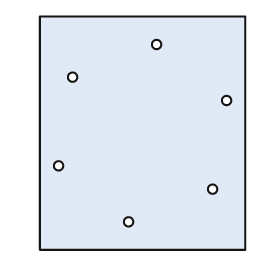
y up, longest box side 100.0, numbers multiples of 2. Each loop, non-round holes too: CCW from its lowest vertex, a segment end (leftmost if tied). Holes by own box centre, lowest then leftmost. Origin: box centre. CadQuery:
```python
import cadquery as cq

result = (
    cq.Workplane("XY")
    .moveTo(-44.0, -50.0)
    .lineTo(44.0, -50.0)
    .lineTo(44.0, 50.0)
    .lineTo(-44.0, 50.0)
    .close()
    .moveTo(-6.0, -38.0)
    .circle(2.0)
    .moveTo(30.0, -24.0)
    .circle(2.0)
    .moveTo(-36.0, -14.0)
    .circle(2.0)
    .moveTo(36.0, 14.0)
    .circle(2.0)
    .moveTo(-30.0, 24.0)
    .circle(2.0)
    .moveTo(6.0, 38.0)
    .circle(2.0)
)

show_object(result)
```